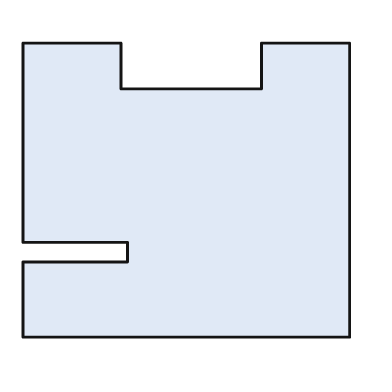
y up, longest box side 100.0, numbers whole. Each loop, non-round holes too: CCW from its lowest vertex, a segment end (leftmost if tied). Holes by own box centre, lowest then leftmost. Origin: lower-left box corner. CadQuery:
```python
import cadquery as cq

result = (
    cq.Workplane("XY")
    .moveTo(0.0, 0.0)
    .lineTo(100.0, 0.0)
    .lineTo(100.0, 90.0)
    .lineTo(73.0, 90.0)
    .lineTo(73.0, 76.0)
    .lineTo(30.0, 76.0)
    .lineTo(30.0, 90.0)
    .lineTo(0.0, 90.0)
    .lineTo(0.0, 29.0)
    .lineTo(32.0, 29.0)
    .lineTo(32.0, 23.0)
    .lineTo(0.0, 23.0)
    .close()
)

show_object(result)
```